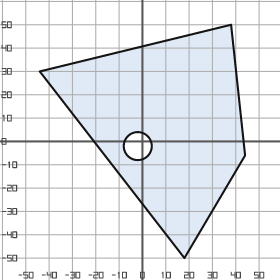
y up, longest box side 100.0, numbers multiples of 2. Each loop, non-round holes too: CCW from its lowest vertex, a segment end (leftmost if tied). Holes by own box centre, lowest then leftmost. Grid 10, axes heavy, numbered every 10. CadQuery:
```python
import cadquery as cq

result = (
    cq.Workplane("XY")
    .moveTo(18.0, -50.0)
    .lineTo(44.0, -6.0)
    .lineTo(38.0, 50.0)
    .lineTo(-44.0, 30.0)
    .close()
    .moveTo(-2.0, -2.0)
    .circle(6.0)
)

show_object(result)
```